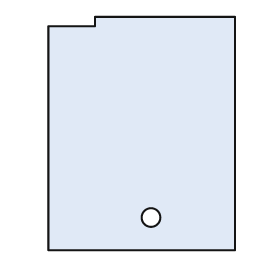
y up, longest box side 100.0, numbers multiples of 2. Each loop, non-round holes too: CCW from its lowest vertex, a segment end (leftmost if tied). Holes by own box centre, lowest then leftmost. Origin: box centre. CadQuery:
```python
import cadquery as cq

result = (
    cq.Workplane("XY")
    .moveTo(-40.0, -50.0)
    .lineTo(40.0, -50.0)
    .lineTo(40.0, 50.0)
    .lineTo(-20.0, 50.0)
    .lineTo(-20.0, 46.0)
    .lineTo(-40.0, 46.0)
    .close()
    .moveTo(4.0, -36.0)
    .circle(4.0)
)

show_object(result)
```